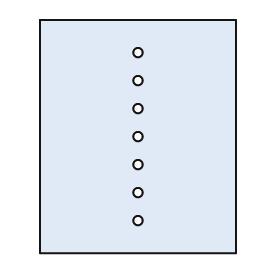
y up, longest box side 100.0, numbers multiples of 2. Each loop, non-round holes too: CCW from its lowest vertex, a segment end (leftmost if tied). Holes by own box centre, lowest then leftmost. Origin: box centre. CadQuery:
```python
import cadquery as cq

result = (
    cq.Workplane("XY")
    .moveTo(-42.0, -50.0)
    .lineTo(42.0, -50.0)
    .lineTo(42.0, 50.0)
    .lineTo(-42.0, 50.0)
    .close()
    .moveTo(0.0, -36.0)
    .circle(2.0)
    .moveTo(0.0, -24.0)
    .circle(2.0)
    .moveTo(0.0, -12.0)
    .circle(2.0)
    .moveTo(0.0, 0.0)
    .circle(2.0)
    .moveTo(0.0, 12.0)
    .circle(2.0)
    .moveTo(0.0, 24.0)
    .circle(2.0)
    .moveTo(0.0, 36.0)
    .circle(2.0)
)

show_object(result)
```